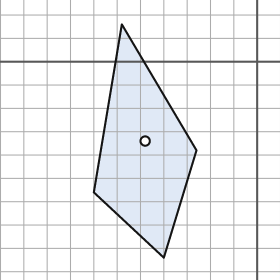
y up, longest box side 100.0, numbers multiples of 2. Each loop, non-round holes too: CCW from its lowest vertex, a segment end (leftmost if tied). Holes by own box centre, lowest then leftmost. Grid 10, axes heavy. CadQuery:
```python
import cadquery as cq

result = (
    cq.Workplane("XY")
    .moveTo(-40.0, -84.0)
    .lineTo(-26.0, -38.0)
    .lineTo(-58.0, 16.0)
    .lineTo(-70.0, -56.0)
    .close()
    .moveTo(-48.0, -34.0)
    .circle(2.0)
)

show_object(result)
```